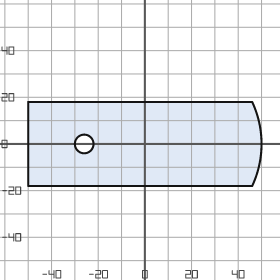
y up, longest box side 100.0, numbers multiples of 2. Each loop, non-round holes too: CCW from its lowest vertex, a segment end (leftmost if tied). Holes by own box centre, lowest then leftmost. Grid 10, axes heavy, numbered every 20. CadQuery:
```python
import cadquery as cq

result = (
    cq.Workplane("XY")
    .moveTo(-50.0, -18.0)
    .lineTo(46.0, -18.0)
    .threePointArc((50.0, 0.0), (46.0, 18.0))
    .lineTo(-50.0, 18.0)
    .close()
    .moveTo(-26.0, 0.0)
    .circle(4.0)
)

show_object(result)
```